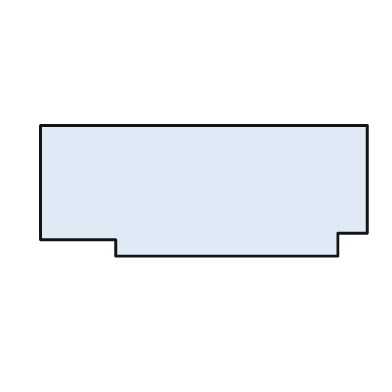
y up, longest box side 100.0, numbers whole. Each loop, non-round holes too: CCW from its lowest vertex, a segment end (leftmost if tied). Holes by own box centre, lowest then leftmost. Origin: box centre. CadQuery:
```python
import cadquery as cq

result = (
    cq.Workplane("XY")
    .moveTo(-27.0, -20.0)
    .lineTo(41.0, -20.0)
    .lineTo(41.0, -13.0)
    .lineTo(50.0, -13.0)
    .lineTo(50.0, 20.0)
    .lineTo(-50.0, 20.0)
    .lineTo(-50.0, -15.0)
    .lineTo(-27.0, -15.0)
    .close()
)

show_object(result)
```